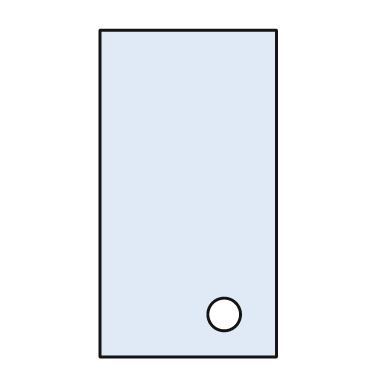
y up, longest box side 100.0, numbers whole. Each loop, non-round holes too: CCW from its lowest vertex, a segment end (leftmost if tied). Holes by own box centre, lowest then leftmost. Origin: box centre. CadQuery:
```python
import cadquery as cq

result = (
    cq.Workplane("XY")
    .moveTo(-27.0, -50.0)
    .lineTo(27.0, -50.0)
    .lineTo(27.0, 50.0)
    .lineTo(-27.0, 50.0)
    .close()
    .moveTo(11.0, -37.0)
    .circle(5.0)
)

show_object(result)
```